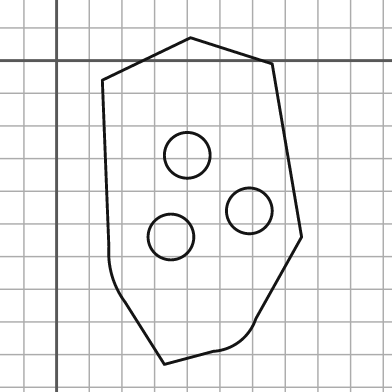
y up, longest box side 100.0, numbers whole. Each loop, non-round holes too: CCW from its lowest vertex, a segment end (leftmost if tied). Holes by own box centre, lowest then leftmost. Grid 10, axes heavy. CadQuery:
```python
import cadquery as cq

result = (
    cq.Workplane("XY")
    .moveTo(33.0, -93.0)
    .lineTo(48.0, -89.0)
    .threePointArc((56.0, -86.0), (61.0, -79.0))
    .lineTo(75.0, -54.0)
    .lineTo(66.0, -1.0)
    .lineTo(41.0, 7.0)
    .lineTo(14.0, -6.0)
    .lineTo(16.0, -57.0)
    .threePointArc((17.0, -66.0), (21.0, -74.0))
    .close()
    .moveTo(35.0, -54.0)
    .circle(7.0)
    .moveTo(59.0, -46.0)
    .circle(7.0)
    .moveTo(40.0, -29.0)
    .circle(7.0)
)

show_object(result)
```